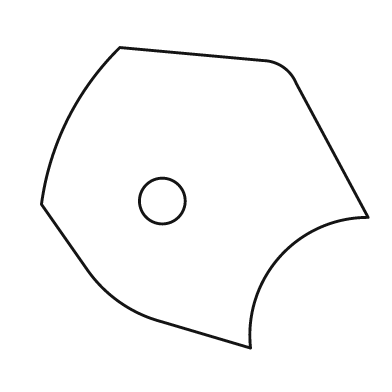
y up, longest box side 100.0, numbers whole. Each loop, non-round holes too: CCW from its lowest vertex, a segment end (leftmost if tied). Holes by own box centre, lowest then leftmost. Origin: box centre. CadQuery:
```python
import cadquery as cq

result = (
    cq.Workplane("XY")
    .moveTo(14.0, -46.0)
    .threePointArc((23.0, -18.0), (50.0, -6.0))
    .lineTo(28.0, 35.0)
    .threePointArc((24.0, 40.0), (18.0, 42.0))
    .lineTo(-26.0, 46.0)
    .threePointArc((-42.0, 24.0), (-50.0, -2.0))
    .lineTo(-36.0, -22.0)
    .threePointArc((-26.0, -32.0), (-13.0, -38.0))
    .close()
    .moveTo(-13.0, -1.0)
    .circle(7.0)
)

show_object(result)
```